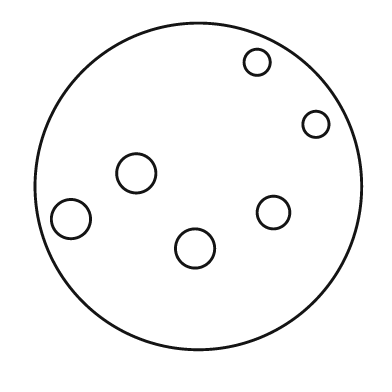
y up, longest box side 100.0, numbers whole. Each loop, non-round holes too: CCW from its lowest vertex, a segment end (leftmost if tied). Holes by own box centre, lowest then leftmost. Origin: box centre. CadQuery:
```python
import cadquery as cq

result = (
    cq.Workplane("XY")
    .moveTo(0.0, 0.0)
    .circle(50.0)
    .moveTo(-1.0, -19.0)
    .circle(6.0)
    .moveTo(-39.0, -10.0)
    .circle(6.0)
    .moveTo(23.0, -8.0)
    .circle(5.0)
    .moveTo(-19.0, 4.0)
    .circle(6.0)
    .moveTo(36.0, 19.0)
    .circle(4.0)
    .moveTo(18.0, 38.0)
    .circle(4.0)
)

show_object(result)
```